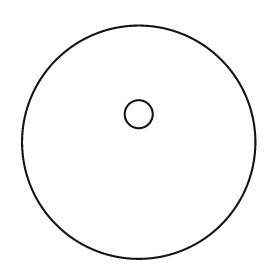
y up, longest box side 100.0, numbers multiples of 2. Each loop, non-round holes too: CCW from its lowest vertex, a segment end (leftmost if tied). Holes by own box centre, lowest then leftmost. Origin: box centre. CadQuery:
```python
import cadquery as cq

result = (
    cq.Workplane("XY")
    .moveTo(0.0, 0.0)
    .circle(50.0)
    .moveTo(0.0, 12.0)
    .circle(6.0)
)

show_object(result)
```